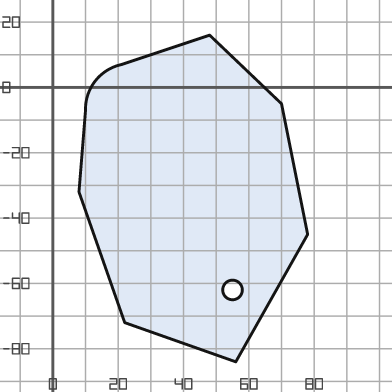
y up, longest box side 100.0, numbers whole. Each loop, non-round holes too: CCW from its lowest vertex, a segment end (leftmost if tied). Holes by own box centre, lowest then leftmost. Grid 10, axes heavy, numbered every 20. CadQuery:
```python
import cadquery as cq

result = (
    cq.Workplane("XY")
    .moveTo(56.0, -84.0)
    .lineTo(78.0, -45.0)
    .lineTo(70.0, -5.0)
    .lineTo(48.0, 16.0)
    .lineTo(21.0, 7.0)
    .threePointArc((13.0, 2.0), (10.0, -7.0))
    .lineTo(8.0, -32.0)
    .lineTo(22.0, -72.0)
    .close()
    .moveTo(55.0, -62.0)
    .circle(3.0)
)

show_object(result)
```